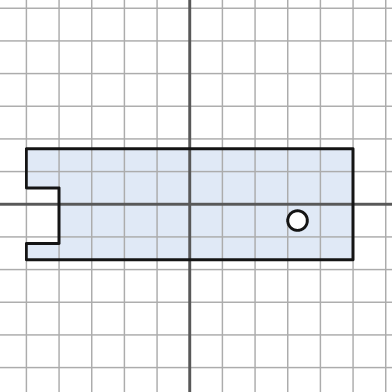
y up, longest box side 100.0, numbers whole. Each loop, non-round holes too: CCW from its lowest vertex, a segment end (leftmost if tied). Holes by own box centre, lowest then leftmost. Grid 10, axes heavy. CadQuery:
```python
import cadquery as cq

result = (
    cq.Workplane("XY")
    .moveTo(-50.0, -17.0)
    .lineTo(50.0, -17.0)
    .lineTo(50.0, 17.0)
    .lineTo(-50.0, 17.0)
    .lineTo(-50.0, 5.0)
    .lineTo(-40.0, 5.0)
    .lineTo(-40.0, -12.0)
    .lineTo(-50.0, -12.0)
    .close()
    .moveTo(33.0, -5.0)
    .circle(3.0)
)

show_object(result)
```